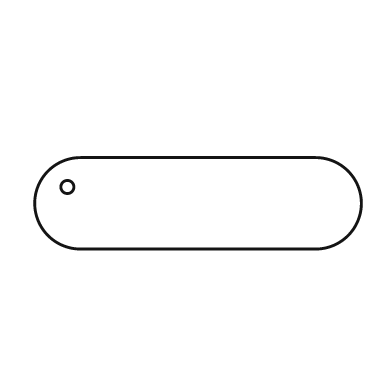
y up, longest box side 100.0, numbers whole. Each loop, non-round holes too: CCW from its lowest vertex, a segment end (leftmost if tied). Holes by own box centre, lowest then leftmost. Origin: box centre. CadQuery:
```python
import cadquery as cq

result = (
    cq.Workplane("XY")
    .moveTo(-36.0, -14.0)
    .lineTo(36.0, -14.0)
    .threePointArc((50.0, 0.0), (36.0, 14.0))
    .lineTo(-36.0, 14.0)
    .threePointArc((-50.0, 0.0), (-36.0, -14.0))
    .close()
    .moveTo(-40.0, 5.0)
    .circle(2.0)
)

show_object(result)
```